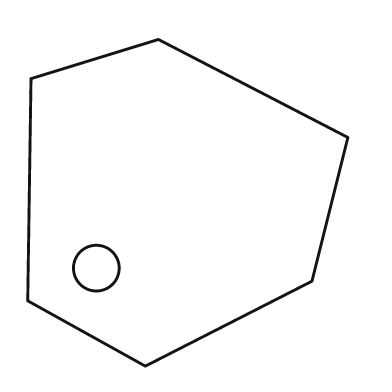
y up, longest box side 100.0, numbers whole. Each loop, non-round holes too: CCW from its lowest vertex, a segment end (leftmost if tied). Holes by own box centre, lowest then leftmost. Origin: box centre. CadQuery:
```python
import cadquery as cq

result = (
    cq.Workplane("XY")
    .moveTo(-13.0, -50.0)
    .lineTo(38.0, -24.0)
    .lineTo(49.0, 20.0)
    .lineTo(-9.0, 50.0)
    .lineTo(-48.0, 38.0)
    .lineTo(-49.0, -30.0)
    .close()
    .moveTo(-28.0, -20.0)
    .circle(7.0)
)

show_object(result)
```